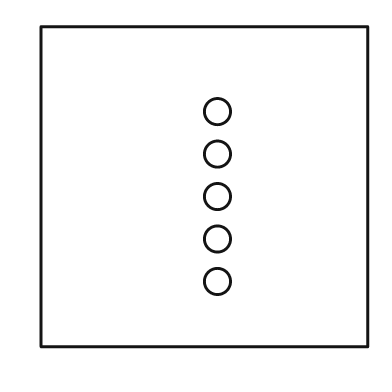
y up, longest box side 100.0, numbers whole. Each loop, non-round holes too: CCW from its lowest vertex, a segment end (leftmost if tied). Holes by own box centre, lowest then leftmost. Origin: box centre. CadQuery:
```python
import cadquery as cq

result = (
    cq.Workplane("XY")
    .moveTo(-50.0, -49.0)
    .lineTo(50.0, -49.0)
    .lineTo(50.0, 49.0)
    .lineTo(-50.0, 49.0)
    .close()
    .moveTo(4.0, -29.0)
    .circle(4.0)
    .moveTo(4.0, -16.0)
    .circle(4.0)
    .moveTo(4.0, -3.0)
    .circle(4.0)
    .moveTo(4.0, 10.0)
    .circle(4.0)
    .moveTo(4.0, 23.0)
    .circle(4.0)
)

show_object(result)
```